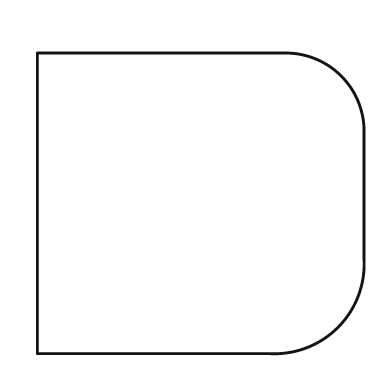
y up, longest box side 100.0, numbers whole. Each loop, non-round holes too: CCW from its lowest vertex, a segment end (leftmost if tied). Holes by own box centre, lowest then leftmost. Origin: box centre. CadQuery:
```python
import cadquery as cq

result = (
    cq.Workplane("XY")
    .moveTo(-50.0, -46.0)
    .lineTo(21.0, -46.0)
    .threePointArc((42.0, -38.0), (50.0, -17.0))
    .lineTo(50.0, 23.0)
    .threePointArc((43.0, 39.0), (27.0, 46.0))
    .lineTo(-50.0, 46.0)
    .close()
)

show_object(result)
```